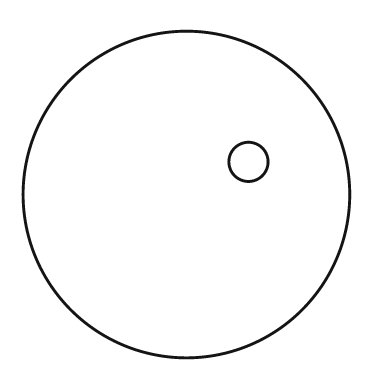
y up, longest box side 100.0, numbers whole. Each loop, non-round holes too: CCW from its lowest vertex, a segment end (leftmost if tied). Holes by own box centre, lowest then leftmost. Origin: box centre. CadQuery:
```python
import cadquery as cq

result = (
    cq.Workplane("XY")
    .moveTo(0.0, 0.0)
    .circle(50.0)
    .moveTo(19.0, 10.0)
    .circle(6.0)
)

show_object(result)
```